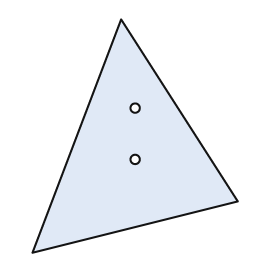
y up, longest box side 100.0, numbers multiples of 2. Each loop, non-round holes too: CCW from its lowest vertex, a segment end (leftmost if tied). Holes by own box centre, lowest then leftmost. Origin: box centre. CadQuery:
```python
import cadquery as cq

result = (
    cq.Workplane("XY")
    .moveTo(-44.0, -50.0)
    .lineTo(44.0, -28.0)
    .lineTo(-6.0, 50.0)
    .close()
    .moveTo(0.0, -10.0)
    .circle(2.0)
    .moveTo(0.0, 12.0)
    .circle(2.0)
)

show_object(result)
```